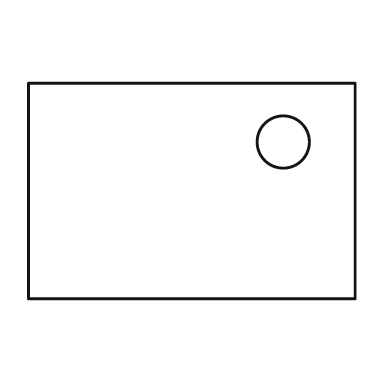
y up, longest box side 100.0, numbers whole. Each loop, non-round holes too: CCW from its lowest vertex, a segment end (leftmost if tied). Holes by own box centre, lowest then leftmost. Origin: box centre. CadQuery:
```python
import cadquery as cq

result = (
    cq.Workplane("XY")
    .moveTo(-50.0, -33.0)
    .lineTo(50.0, -33.0)
    .lineTo(50.0, 33.0)
    .lineTo(-50.0, 33.0)
    .close()
    .moveTo(28.0, 15.0)
    .circle(8.0)
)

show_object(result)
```